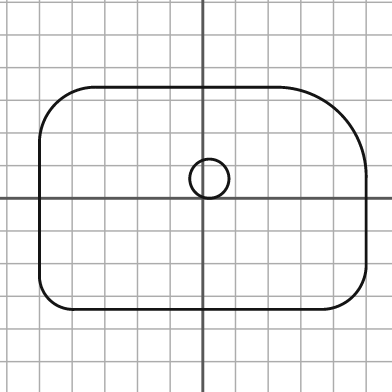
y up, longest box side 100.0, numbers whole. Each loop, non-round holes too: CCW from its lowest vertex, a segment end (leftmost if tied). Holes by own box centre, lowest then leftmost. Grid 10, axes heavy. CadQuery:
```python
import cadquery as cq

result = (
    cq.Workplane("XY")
    .moveTo(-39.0, -34.0)
    .lineTo(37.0, -34.0)
    .threePointArc((46.0, -30.0), (50.0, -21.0))
    .lineTo(50.0, 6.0)
    .threePointArc((42.0, 26.0), (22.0, 34.0))
    .lineTo(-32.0, 34.0)
    .threePointArc((-45.0, 29.0), (-50.0, 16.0))
    .lineTo(-50.0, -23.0)
    .threePointArc((-47.0, -31.0), (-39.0, -34.0))
    .close()
    .moveTo(2.0, 6.0)
    .circle(6.0)
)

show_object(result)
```